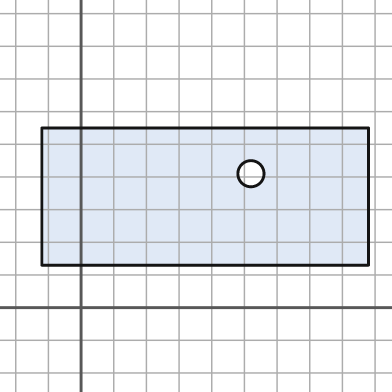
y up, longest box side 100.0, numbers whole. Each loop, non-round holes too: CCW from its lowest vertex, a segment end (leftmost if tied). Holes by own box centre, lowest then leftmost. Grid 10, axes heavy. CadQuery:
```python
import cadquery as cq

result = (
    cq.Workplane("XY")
    .moveTo(-12.0, 13.0)
    .lineTo(88.0, 13.0)
    .lineTo(88.0, 55.0)
    .lineTo(-12.0, 55.0)
    .close()
    .moveTo(52.0, 41.0)
    .circle(4.0)
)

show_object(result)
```